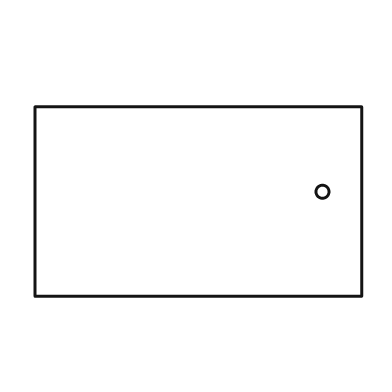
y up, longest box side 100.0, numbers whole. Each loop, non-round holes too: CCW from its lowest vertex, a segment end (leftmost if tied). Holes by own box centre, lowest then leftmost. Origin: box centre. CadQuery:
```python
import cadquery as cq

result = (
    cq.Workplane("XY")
    .moveTo(-50.0, -29.0)
    .lineTo(50.0, -29.0)
    .lineTo(50.0, 29.0)
    .lineTo(-50.0, 29.0)
    .close()
    .moveTo(38.0, 3.0)
    .circle(2.0)
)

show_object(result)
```